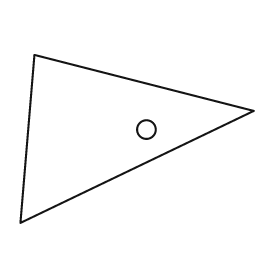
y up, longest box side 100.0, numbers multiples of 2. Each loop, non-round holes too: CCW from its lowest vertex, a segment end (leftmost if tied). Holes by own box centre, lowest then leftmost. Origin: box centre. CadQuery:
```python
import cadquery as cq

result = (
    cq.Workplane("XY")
    .moveTo(-50.0, -36.0)
    .lineTo(50.0, 12.0)
    .lineTo(-44.0, 36.0)
    .close()
    .moveTo(4.0, 4.0)
    .circle(4.0)
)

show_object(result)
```